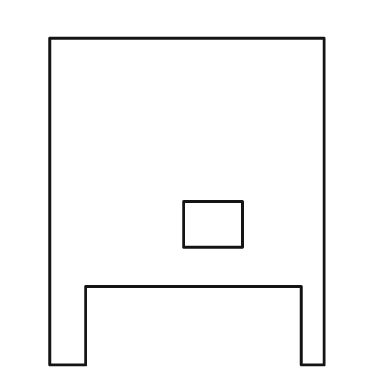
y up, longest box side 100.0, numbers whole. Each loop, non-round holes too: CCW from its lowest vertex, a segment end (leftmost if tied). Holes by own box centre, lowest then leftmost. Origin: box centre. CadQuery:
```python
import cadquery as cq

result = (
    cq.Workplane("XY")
    .moveTo(-42.0, -50.0)
    .lineTo(-31.0, -50.0)
    .lineTo(-31.0, -26.0)
    .lineTo(35.0, -26.0)
    .lineTo(35.0, -50.0)
    .lineTo(42.0, -50.0)
    .lineTo(42.0, 50.0)
    .lineTo(-42.0, 50.0)
    .close()
    .moveTo(-1.0, -14.0)
    .lineTo(17.0, -14.0)
    .lineTo(17.0, 0.0)
    .lineTo(-1.0, 0.0)
    .close()
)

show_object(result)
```